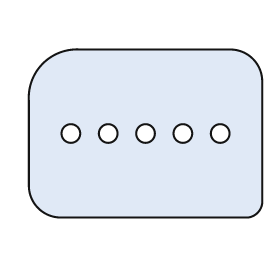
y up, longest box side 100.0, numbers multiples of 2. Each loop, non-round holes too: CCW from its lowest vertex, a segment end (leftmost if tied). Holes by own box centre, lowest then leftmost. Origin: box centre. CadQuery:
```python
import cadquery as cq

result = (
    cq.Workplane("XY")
    .moveTo(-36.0, -36.0)
    .lineTo(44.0, -36.0)
    .threePointArc((48.0, -34.0), (50.0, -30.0))
    .lineTo(50.0, 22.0)
    .threePointArc((46.0, 32.0), (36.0, 36.0))
    .lineTo(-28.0, 36.0)
    .threePointArc((-44.0, 30.0), (-50.0, 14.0))
    .lineTo(-50.0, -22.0)
    .threePointArc((-46.0, -32.0), (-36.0, -36.0))
    .close()
    .moveTo(-32.0, 0.0)
    .circle(4.0)
    .moveTo(-16.0, 0.0)
    .circle(4.0)
    .moveTo(0.0, 0.0)
    .circle(4.0)
    .moveTo(16.0, 0.0)
    .circle(4.0)
    .moveTo(32.0, 0.0)
    .circle(4.0)
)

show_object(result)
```